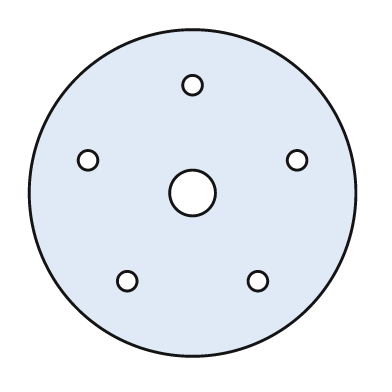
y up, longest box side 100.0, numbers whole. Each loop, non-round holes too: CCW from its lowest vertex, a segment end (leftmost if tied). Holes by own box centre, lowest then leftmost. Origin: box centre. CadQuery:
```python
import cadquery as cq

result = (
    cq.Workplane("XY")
    .moveTo(0.0, 0.0)
    .circle(50.0)
    .moveTo(-20.0, -27.0)
    .circle(3.0)
    .moveTo(20.0, -27.0)
    .circle(3.0)
    .moveTo(0.0, 0.0)
    .circle(7.0)
    .moveTo(-32.0, 10.0)
    .circle(3.0)
    .moveTo(32.0, 10.0)
    .circle(3.0)
    .moveTo(0.0, 33.0)
    .circle(3.0)
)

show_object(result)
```